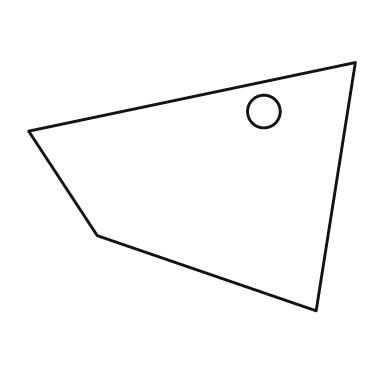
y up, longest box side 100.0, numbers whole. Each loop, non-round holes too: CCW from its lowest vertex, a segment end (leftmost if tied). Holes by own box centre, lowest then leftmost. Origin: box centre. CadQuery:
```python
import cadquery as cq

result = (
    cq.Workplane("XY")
    .moveTo(38.0, -38.0)
    .lineTo(50.0, 38.0)
    .lineTo(-50.0, 17.0)
    .lineTo(-29.0, -15.0)
    .close()
    .moveTo(22.0, 23.0)
    .circle(5.0)
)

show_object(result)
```